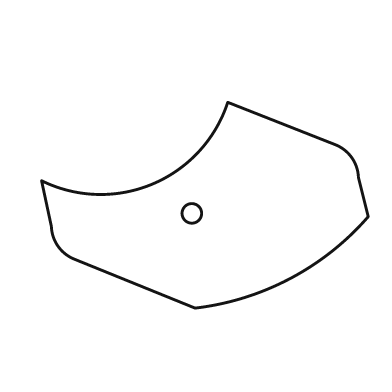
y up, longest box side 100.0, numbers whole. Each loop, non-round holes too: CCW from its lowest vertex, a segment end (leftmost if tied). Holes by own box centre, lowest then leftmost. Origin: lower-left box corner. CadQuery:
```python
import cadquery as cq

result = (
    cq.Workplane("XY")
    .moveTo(47.0, 0.0)
    .threePointArc((76.0, 9.0), (100.0, 28.0))
    .lineTo(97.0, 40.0)
    .threePointArc((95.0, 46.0), (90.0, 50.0))
    .lineTo(57.0, 63.0)
    .threePointArc((34.0, 38.0), (0.0, 39.0))
    .lineTo(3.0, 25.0)
    .threePointArc((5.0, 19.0), (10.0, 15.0))
    .close()
    .moveTo(46.0, 29.0)
    .circle(3.0)
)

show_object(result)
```